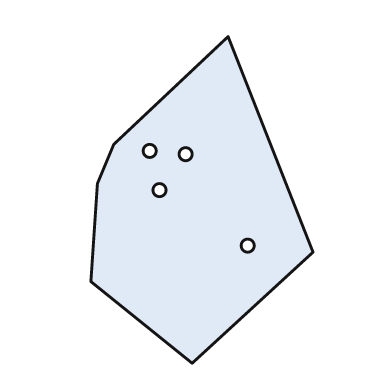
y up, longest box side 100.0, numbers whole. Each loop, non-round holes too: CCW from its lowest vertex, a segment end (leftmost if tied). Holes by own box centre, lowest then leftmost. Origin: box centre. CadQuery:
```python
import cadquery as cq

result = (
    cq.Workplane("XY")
    .moveTo(-3.0, -50.0)
    .lineTo(34.0, -16.0)
    .lineTo(8.0, 50.0)
    .lineTo(-27.0, 17.0)
    .lineTo(-32.0, 5.0)
    .lineTo(-34.0, -25.0)
    .close()
    .moveTo(14.0, -14.0)
    .circle(2.0)
    .moveTo(-13.0, 3.0)
    .circle(2.0)
    .moveTo(-5.0, 14.0)
    .circle(2.0)
    .moveTo(-16.0, 15.0)
    .circle(2.0)
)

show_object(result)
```